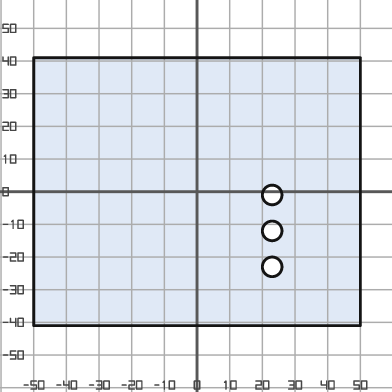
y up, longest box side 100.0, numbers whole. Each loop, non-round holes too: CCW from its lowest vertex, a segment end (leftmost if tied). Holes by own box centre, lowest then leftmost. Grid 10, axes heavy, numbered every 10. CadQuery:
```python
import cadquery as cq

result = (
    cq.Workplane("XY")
    .moveTo(-50.0, -41.0)
    .lineTo(50.0, -41.0)
    .lineTo(50.0, 41.0)
    .lineTo(-50.0, 41.0)
    .close()
    .moveTo(23.0, -23.0)
    .circle(3.0)
    .moveTo(23.0, -12.0)
    .circle(3.0)
    .moveTo(23.0, -1.0)
    .circle(3.0)
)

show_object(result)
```